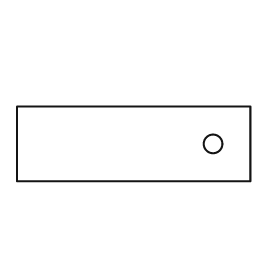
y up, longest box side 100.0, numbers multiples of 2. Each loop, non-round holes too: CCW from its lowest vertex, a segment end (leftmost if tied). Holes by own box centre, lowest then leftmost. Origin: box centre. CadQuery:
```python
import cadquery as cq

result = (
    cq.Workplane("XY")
    .moveTo(-50.0, -16.0)
    .lineTo(50.0, -16.0)
    .lineTo(50.0, 16.0)
    .lineTo(-50.0, 16.0)
    .close()
    .moveTo(34.0, 0.0)
    .circle(4.0)
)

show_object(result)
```